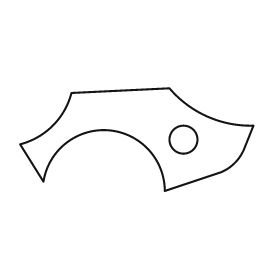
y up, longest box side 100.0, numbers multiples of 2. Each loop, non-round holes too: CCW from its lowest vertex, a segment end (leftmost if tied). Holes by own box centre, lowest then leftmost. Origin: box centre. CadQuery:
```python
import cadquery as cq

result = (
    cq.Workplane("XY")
    .moveTo(12.0, -22.0)
    .lineTo(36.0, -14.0)
    .threePointArc((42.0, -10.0), (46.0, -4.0))
    .lineTo(50.0, 6.0)
    .threePointArc((30.0, 10.0), (14.0, 22.0))
    .lineTo(-28.0, 20.0)
    .threePointArc((-36.0, 6.0), (-50.0, -2.0))
    .lineTo(-40.0, -18.0)
    .threePointArc((-12.0, 4.0), (12.0, -22.0))
    .close()
    .moveTo(20.0, 0.0)
    .circle(6.0)
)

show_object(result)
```